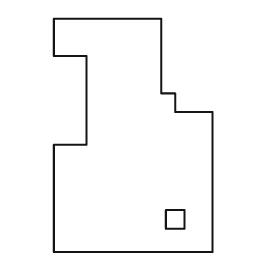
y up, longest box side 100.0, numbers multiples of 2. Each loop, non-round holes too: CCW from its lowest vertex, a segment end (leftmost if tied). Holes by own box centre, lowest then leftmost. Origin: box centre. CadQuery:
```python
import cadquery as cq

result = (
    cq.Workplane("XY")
    .moveTo(-34.0, -50.0)
    .lineTo(34.0, -50.0)
    .lineTo(34.0, 10.0)
    .lineTo(18.0, 10.0)
    .lineTo(18.0, 18.0)
    .lineTo(12.0, 18.0)
    .lineTo(12.0, 50.0)
    .lineTo(-34.0, 50.0)
    .lineTo(-34.0, 34.0)
    .lineTo(-20.0, 34.0)
    .lineTo(-20.0, -4.0)
    .lineTo(-34.0, -4.0)
    .close()
    .moveTo(14.0, -40.0)
    .lineTo(22.0, -40.0)
    .lineTo(22.0, -32.0)
    .lineTo(14.0, -32.0)
    .close()
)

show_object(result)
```